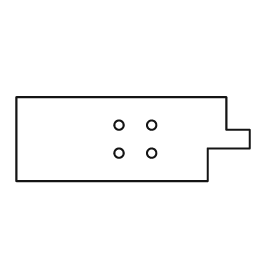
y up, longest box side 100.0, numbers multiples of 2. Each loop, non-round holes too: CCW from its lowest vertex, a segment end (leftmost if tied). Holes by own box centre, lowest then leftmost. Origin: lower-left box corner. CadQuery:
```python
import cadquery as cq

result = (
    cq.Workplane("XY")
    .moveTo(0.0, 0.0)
    .lineTo(82.0, 0.0)
    .lineTo(82.0, 14.0)
    .lineTo(100.0, 14.0)
    .lineTo(100.0, 22.0)
    .lineTo(90.0, 22.0)
    .lineTo(90.0, 36.0)
    .lineTo(0.0, 36.0)
    .close()
    .moveTo(44.0, 12.0)
    .circle(2.0)
    .moveTo(58.0, 12.0)
    .circle(2.0)
    .moveTo(44.0, 24.0)
    .circle(2.0)
    .moveTo(58.0, 24.0)
    .circle(2.0)
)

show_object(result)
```